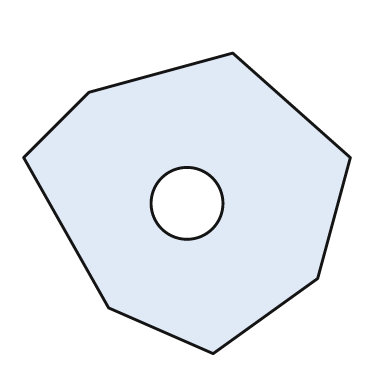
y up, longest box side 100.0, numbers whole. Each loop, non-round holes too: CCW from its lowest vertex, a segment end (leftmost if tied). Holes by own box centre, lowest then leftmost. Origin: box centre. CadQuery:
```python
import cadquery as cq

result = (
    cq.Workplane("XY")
    .moveTo(8.0, -46.0)
    .lineTo(40.0, -23.0)
    .lineTo(50.0, 14.0)
    .lineTo(14.0, 46.0)
    .lineTo(-30.0, 34.0)
    .lineTo(-50.0, 14.0)
    .lineTo(-24.0, -32.0)
    .close()
    .moveTo(0.0, 0.0)
    .circle(11.0)
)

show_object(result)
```